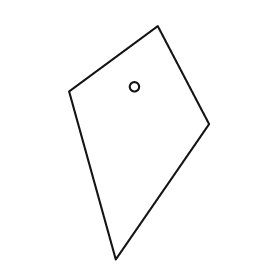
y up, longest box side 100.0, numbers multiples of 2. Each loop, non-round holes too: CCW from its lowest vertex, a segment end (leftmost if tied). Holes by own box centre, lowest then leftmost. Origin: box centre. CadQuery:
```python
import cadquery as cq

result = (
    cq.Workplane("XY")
    .moveTo(-10.0, -50.0)
    .lineTo(30.0, 8.0)
    .lineTo(8.0, 50.0)
    .lineTo(-30.0, 22.0)
    .close()
    .moveTo(-2.0, 24.0)
    .circle(2.0)
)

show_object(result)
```